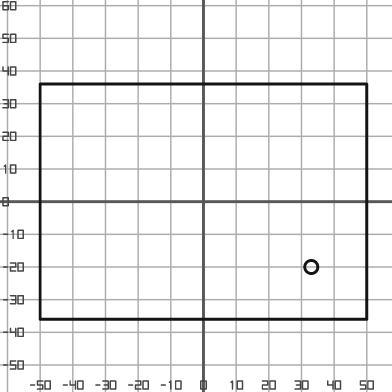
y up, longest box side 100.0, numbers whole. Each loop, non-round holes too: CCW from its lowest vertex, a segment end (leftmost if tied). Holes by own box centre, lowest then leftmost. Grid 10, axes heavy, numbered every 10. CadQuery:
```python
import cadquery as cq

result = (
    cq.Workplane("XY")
    .moveTo(-50.0, -36.0)
    .lineTo(50.0, -36.0)
    .lineTo(50.0, 36.0)
    .lineTo(-50.0, 36.0)
    .close()
    .moveTo(33.0, -20.0)
    .circle(2.0)
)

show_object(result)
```